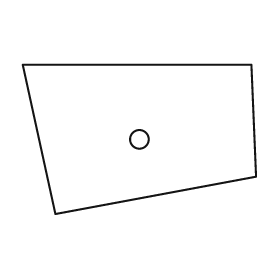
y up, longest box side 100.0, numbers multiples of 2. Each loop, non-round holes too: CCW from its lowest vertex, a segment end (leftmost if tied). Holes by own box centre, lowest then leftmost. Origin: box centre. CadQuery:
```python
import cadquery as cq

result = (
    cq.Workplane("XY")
    .moveTo(-36.0, -32.0)
    .lineTo(50.0, -16.0)
    .lineTo(48.0, 32.0)
    .lineTo(-50.0, 32.0)
    .close()
    .moveTo(0.0, 0.0)
    .circle(4.0)
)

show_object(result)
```